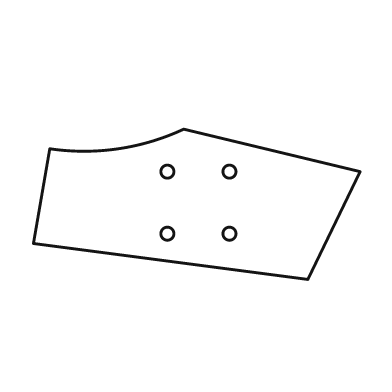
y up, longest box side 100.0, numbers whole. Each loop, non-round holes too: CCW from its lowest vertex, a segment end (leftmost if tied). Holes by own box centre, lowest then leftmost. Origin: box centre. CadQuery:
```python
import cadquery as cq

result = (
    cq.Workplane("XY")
    .moveTo(34.0, -23.0)
    .lineTo(50.0, 10.0)
    .lineTo(-4.0, 23.0)
    .threePointArc((-24.0, 17.0), (-45.0, 17.0))
    .lineTo(-50.0, -12.0)
    .close()
    .moveTo(-9.0, -9.0)
    .circle(2.0)
    .moveTo(10.0, -9.0)
    .circle(2.0)
    .moveTo(-9.0, 10.0)
    .circle(2.0)
    .moveTo(10.0, 10.0)
    .circle(2.0)
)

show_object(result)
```